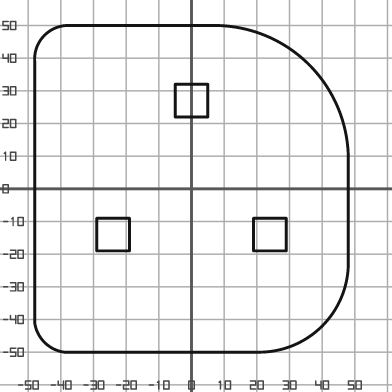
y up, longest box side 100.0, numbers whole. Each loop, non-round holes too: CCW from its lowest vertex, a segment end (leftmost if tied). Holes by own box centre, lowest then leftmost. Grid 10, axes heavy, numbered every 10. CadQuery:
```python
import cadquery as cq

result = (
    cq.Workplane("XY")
    .moveTo(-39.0, -50.0)
    .lineTo(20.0, -50.0)
    .threePointArc((40.0, -42.0), (48.0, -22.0))
    .lineTo(48.0, 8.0)
    .threePointArc((36.0, 38.0), (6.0, 50.0))
    .lineTo(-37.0, 50.0)
    .threePointArc((-45.0, 47.0), (-48.0, 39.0))
    .lineTo(-48.0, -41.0)
    .threePointArc((-45.0, -47.0), (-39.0, -50.0))
    .close()
    .moveTo(-29.0, -19.0)
    .lineTo(-19.0, -19.0)
    .lineTo(-19.0, -9.0)
    .lineTo(-29.0, -9.0)
    .close()
    .moveTo(19.0, -19.0)
    .lineTo(29.0, -19.0)
    .lineTo(29.0, -9.0)
    .lineTo(19.0, -9.0)
    .close()
    .moveTo(-5.0, 22.0)
    .lineTo(5.0, 22.0)
    .lineTo(5.0, 32.0)
    .lineTo(-5.0, 32.0)
    .close()
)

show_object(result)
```